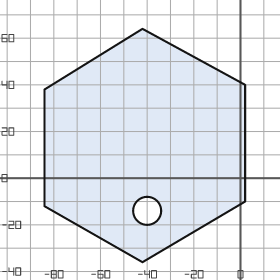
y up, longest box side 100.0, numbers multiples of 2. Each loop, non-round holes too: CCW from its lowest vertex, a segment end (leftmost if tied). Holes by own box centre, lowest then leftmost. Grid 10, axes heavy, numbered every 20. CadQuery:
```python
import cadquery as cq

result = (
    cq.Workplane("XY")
    .moveTo(-42.0, -36.0)
    .lineTo(2.0, -10.0)
    .lineTo(2.0, 40.0)
    .lineTo(-42.0, 64.0)
    .lineTo(-84.0, 38.0)
    .lineTo(-84.0, -12.0)
    .close()
    .moveTo(-40.0, -14.0)
    .circle(6.0)
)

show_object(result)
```